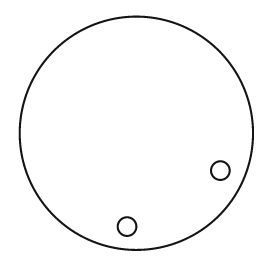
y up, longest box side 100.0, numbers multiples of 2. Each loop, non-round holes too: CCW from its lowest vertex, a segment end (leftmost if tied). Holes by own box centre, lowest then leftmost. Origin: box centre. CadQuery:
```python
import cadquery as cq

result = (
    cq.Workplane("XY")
    .moveTo(0.0, 0.0)
    .circle(50.0)
    .moveTo(-4.0, -40.0)
    .circle(4.0)
    .moveTo(36.0, -16.0)
    .circle(4.0)
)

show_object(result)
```